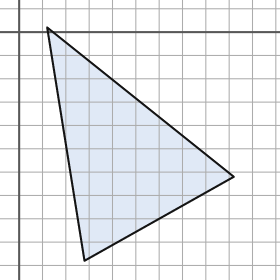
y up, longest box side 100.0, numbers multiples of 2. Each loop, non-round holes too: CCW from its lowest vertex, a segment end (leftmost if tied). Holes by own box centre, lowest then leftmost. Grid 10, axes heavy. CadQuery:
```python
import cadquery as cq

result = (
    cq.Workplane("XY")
    .moveTo(28.0, -98.0)
    .lineTo(92.0, -62.0)
    .lineTo(12.0, 2.0)
    .close()
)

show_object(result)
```